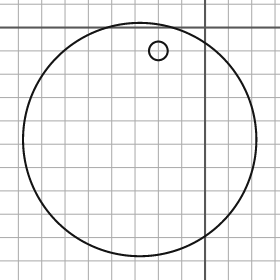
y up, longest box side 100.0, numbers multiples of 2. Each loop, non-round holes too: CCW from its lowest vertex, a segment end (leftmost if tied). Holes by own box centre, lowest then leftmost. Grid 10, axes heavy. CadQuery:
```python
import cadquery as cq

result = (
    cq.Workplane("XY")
    .moveTo(-28.0, -48.0)
    .circle(50.0)
    .moveTo(-20.0, -10.0)
    .circle(4.0)
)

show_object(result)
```